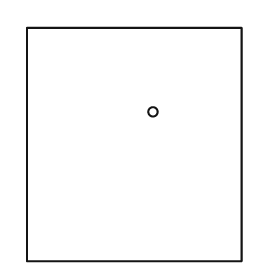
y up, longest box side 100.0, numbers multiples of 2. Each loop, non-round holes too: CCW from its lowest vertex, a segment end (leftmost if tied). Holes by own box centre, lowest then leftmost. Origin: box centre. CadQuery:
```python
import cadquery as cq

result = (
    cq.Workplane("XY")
    .moveTo(-46.0, -50.0)
    .lineTo(46.0, -50.0)
    .lineTo(46.0, 50.0)
    .lineTo(-46.0, 50.0)
    .close()
    .moveTo(8.0, 14.0)
    .circle(2.0)
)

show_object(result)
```